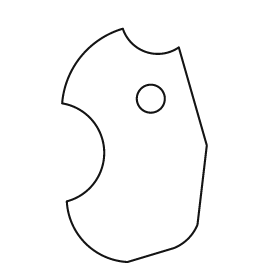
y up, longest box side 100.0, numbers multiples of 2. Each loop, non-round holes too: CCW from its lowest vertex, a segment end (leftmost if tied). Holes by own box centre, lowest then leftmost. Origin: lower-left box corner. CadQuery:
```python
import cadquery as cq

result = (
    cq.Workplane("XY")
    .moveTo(28.0, 0.0)
    .lineTo(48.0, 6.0)
    .threePointArc((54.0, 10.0), (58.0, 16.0))
    .lineTo(62.0, 50.0)
    .lineTo(50.0, 92.0)
    .threePointArc((36.0, 90.0), (26.0, 100.0))
    .threePointArc((8.0, 88.0), (0.0, 68.0))
    .threePointArc((18.0, 48.0), (2.0, 26.0))
    .threePointArc((10.0, 8.0), (28.0, 0.0))
    .close()
    .moveTo(38.0, 70.0)
    .circle(6.0)
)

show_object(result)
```